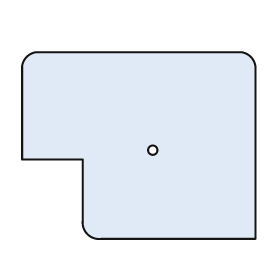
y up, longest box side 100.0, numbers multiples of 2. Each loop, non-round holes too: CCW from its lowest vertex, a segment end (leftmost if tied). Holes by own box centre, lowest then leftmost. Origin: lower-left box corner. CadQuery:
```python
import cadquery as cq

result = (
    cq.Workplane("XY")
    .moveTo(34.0, 0.0)
    .lineTo(100.0, 0.0)
    .lineTo(100.0, 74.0)
    .threePointArc((98.0, 78.0), (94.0, 80.0))
    .lineTo(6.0, 80.0)
    .threePointArc((2.0, 78.0), (0.0, 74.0))
    .lineTo(0.0, 34.0)
    .lineTo(26.0, 34.0)
    .lineTo(26.0, 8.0)
    .threePointArc((28.0, 2.0), (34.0, 0.0))
    .close()
    .moveTo(56.0, 38.0)
    .circle(2.0)
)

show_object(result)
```